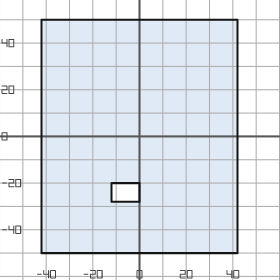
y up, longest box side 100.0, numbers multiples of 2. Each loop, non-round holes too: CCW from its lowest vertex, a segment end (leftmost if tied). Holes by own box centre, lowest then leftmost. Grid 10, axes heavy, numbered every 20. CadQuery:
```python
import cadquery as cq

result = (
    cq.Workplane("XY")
    .moveTo(-42.0, -50.0)
    .lineTo(42.0, -50.0)
    .lineTo(42.0, 50.0)
    .lineTo(-42.0, 50.0)
    .close()
    .moveTo(-12.0, -28.0)
    .lineTo(0.0, -28.0)
    .lineTo(0.0, -20.0)
    .lineTo(-12.0, -20.0)
    .close()
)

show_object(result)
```